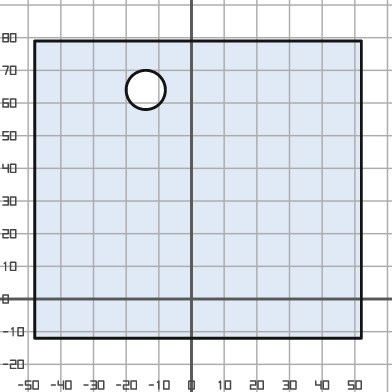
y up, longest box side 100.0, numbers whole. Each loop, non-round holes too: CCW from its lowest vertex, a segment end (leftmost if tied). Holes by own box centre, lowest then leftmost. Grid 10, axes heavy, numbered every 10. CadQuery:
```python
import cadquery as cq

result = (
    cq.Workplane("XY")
    .moveTo(-48.0, -12.0)
    .lineTo(52.0, -12.0)
    .lineTo(52.0, 79.0)
    .lineTo(-48.0, 79.0)
    .close()
    .moveTo(-14.0, 64.0)
    .circle(6.0)
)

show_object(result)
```